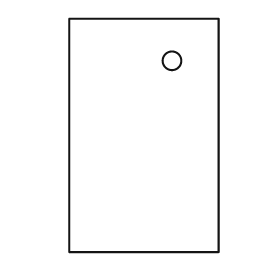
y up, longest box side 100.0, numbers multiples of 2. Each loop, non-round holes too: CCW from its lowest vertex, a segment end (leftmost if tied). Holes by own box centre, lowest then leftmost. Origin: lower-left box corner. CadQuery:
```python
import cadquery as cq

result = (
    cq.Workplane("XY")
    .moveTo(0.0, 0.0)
    .lineTo(64.0, 0.0)
    .lineTo(64.0, 100.0)
    .lineTo(0.0, 100.0)
    .close()
    .moveTo(44.0, 82.0)
    .circle(4.0)
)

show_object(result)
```